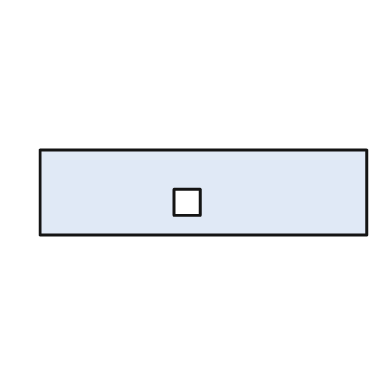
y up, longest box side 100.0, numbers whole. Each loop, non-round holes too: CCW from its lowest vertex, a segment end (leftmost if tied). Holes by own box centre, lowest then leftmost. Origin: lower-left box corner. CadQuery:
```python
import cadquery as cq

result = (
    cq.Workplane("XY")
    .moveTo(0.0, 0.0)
    .lineTo(100.0, 0.0)
    .lineTo(100.0, 26.0)
    .lineTo(0.0, 26.0)
    .close()
    .moveTo(41.0, 6.0)
    .lineTo(49.0, 6.0)
    .lineTo(49.0, 14.0)
    .lineTo(41.0, 14.0)
    .close()
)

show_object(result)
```